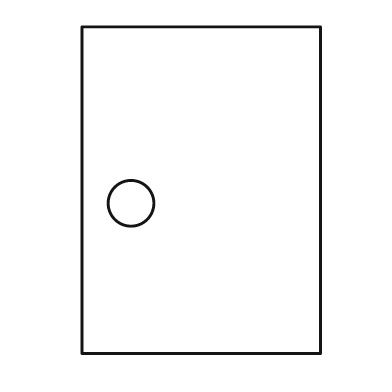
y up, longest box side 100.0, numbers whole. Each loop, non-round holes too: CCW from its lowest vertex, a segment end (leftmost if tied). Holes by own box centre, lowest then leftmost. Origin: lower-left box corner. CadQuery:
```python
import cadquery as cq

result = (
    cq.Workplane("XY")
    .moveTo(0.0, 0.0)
    .lineTo(73.0, 0.0)
    .lineTo(73.0, 100.0)
    .lineTo(0.0, 100.0)
    .close()
    .moveTo(15.0, 46.0)
    .circle(7.0)
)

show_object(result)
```